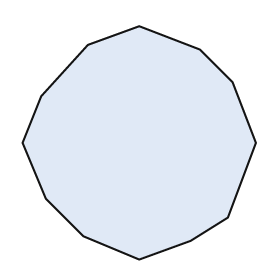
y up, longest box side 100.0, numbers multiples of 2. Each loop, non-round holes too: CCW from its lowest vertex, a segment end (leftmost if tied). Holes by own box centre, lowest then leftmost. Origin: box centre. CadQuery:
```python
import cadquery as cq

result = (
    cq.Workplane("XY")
    .moveTo(0.0, -50.0)
    .lineTo(22.0, -42.0)
    .lineTo(38.0, -32.0)
    .lineTo(50.0, 0.0)
    .lineTo(40.0, 26.0)
    .lineTo(26.0, 40.0)
    .lineTo(0.0, 50.0)
    .lineTo(-22.0, 42.0)
    .lineTo(-42.0, 20.0)
    .lineTo(-50.0, 0.0)
    .lineTo(-40.0, -24.0)
    .lineTo(-24.0, -40.0)
    .close()
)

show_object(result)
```